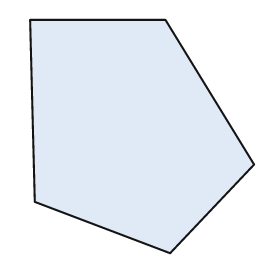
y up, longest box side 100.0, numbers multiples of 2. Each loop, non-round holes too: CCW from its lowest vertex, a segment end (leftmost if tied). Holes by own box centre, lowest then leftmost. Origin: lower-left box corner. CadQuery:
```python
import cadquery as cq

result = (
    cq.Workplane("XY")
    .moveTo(60.0, 0.0)
    .lineTo(96.0, 38.0)
    .lineTo(58.0, 100.0)
    .lineTo(0.0, 100.0)
    .lineTo(2.0, 22.0)
    .close()
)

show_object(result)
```